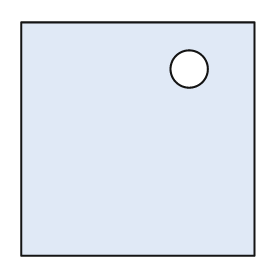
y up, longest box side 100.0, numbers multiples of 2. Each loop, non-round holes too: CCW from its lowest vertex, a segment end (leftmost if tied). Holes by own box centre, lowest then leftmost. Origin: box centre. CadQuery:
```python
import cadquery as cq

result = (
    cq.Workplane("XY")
    .moveTo(-50.0, -50.0)
    .lineTo(50.0, -50.0)
    .lineTo(50.0, 50.0)
    .lineTo(-50.0, 50.0)
    .close()
    .moveTo(22.0, 30.0)
    .circle(8.0)
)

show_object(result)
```